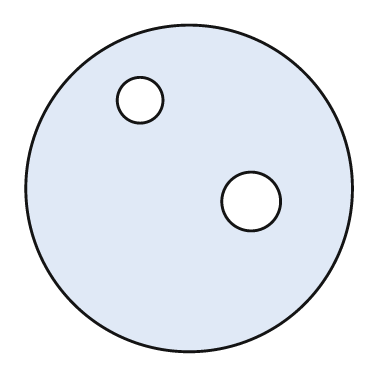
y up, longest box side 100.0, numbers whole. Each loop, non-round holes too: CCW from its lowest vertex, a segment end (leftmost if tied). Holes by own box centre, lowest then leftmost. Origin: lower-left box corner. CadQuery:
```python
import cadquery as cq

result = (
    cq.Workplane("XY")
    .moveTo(50.0, 50.0)
    .circle(50.0)
    .moveTo(69.0, 46.0)
    .circle(9.0)
    .moveTo(35.0, 77.0)
    .circle(7.0)
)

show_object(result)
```